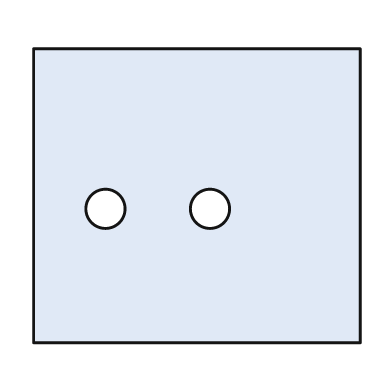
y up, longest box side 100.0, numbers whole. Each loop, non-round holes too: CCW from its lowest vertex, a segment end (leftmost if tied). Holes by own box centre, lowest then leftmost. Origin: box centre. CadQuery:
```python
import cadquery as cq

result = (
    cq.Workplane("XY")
    .moveTo(-50.0, -45.0)
    .lineTo(50.0, -45.0)
    .lineTo(50.0, 45.0)
    .lineTo(-50.0, 45.0)
    .close()
    .moveTo(-28.0, -4.0)
    .circle(6.0)
    .moveTo(4.0, -4.0)
    .circle(6.0)
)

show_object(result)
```